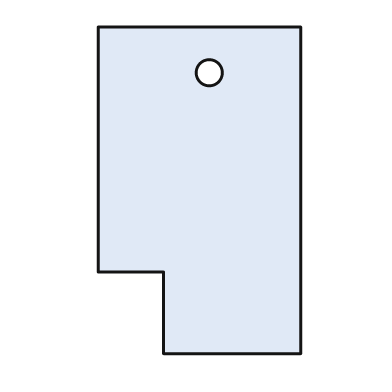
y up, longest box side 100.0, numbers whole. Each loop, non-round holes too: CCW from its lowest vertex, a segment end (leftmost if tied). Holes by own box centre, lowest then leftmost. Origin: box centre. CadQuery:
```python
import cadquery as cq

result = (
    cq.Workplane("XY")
    .moveTo(-11.0, -50.0)
    .lineTo(31.0, -50.0)
    .lineTo(31.0, 50.0)
    .lineTo(-31.0, 50.0)
    .lineTo(-31.0, -25.0)
    .lineTo(-11.0, -25.0)
    .close()
    .moveTo(3.0, 36.0)
    .circle(4.0)
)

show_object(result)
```